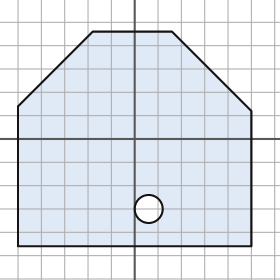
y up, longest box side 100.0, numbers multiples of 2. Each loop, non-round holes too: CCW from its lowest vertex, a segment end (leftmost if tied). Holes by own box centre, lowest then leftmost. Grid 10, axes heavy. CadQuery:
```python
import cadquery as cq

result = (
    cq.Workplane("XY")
    .moveTo(-50.0, -46.0)
    .lineTo(50.0, -46.0)
    .lineTo(50.0, 12.0)
    .lineTo(16.0, 46.0)
    .lineTo(-18.0, 46.0)
    .lineTo(-50.0, 14.0)
    .close()
    .moveTo(6.0, -30.0)
    .circle(6.0)
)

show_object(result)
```